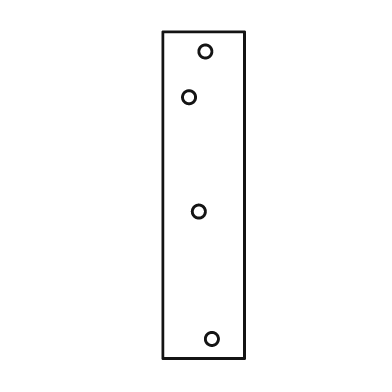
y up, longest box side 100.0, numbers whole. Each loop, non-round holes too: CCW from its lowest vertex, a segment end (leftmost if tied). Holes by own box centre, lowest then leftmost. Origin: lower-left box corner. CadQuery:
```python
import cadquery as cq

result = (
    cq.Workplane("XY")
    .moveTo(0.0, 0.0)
    .lineTo(25.0, 0.0)
    .lineTo(25.0, 100.0)
    .lineTo(0.0, 100.0)
    .close()
    .moveTo(15.0, 6.0)
    .circle(2.0)
    .moveTo(11.0, 45.0)
    .circle(2.0)
    .moveTo(8.0, 80.0)
    .circle(2.0)
    .moveTo(13.0, 94.0)
    .circle(2.0)
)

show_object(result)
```